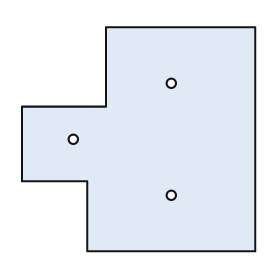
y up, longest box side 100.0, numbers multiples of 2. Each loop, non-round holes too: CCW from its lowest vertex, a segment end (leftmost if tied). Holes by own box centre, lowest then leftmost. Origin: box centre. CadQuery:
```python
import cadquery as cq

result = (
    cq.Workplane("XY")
    .moveTo(-22.0, -48.0)
    .lineTo(50.0, -48.0)
    .lineTo(50.0, 48.0)
    .lineTo(-14.0, 48.0)
    .lineTo(-14.0, 14.0)
    .lineTo(-50.0, 14.0)
    .lineTo(-50.0, -18.0)
    .lineTo(-22.0, -18.0)
    .close()
    .moveTo(14.0, -24.0)
    .circle(2.0)
    .moveTo(-28.0, 0.0)
    .circle(2.0)
    .moveTo(14.0, 24.0)
    .circle(2.0)
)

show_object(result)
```